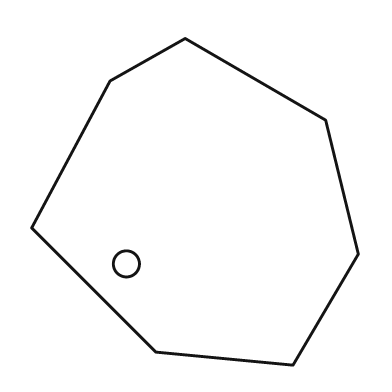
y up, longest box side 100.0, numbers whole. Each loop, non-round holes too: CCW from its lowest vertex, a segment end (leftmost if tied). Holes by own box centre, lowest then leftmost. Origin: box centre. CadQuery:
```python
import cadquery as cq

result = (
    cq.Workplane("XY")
    .moveTo(30.0, -50.0)
    .lineTo(50.0, -16.0)
    .lineTo(40.0, 25.0)
    .lineTo(-3.0, 50.0)
    .lineTo(-26.0, 37.0)
    .lineTo(-50.0, -8.0)
    .lineTo(-12.0, -46.0)
    .close()
    .moveTo(-21.0, -19.0)
    .circle(4.0)
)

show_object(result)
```